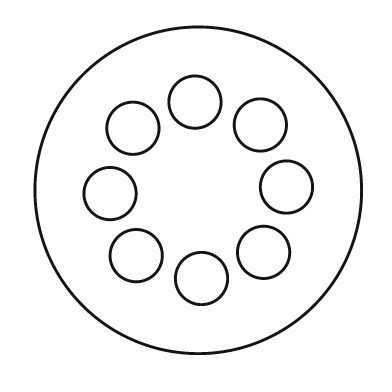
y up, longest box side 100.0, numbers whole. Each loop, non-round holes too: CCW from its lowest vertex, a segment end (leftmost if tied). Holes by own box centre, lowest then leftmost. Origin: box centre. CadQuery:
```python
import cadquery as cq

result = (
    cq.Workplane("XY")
    .moveTo(0.0, 0.0)
    .circle(50.0)
    .moveTo(1.0, -27.0)
    .circle(8.0)
    .moveTo(-19.0, -20.0)
    .circle(8.0)
    .moveTo(20.0, -19.0)
    .circle(8.0)
    .moveTo(-27.0, -1.0)
    .circle(8.0)
    .moveTo(27.0, 1.0)
    .circle(8.0)
    .moveTo(-20.0, 19.0)
    .circle(8.0)
    .moveTo(19.0, 20.0)
    .circle(8.0)
    .moveTo(-1.0, 27.0)
    .circle(8.0)
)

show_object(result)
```